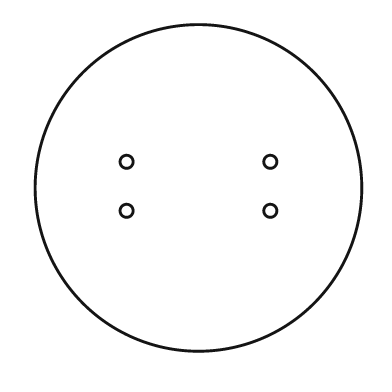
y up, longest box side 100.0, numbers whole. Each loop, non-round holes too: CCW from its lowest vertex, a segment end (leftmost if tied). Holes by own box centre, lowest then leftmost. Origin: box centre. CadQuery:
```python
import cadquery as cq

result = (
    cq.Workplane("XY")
    .moveTo(0.0, 0.0)
    .circle(50.0)
    .moveTo(-22.0, -7.0)
    .circle(2.0)
    .moveTo(22.0, -7.0)
    .circle(2.0)
    .moveTo(-22.0, 8.0)
    .circle(2.0)
    .moveTo(22.0, 8.0)
    .circle(2.0)
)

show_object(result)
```